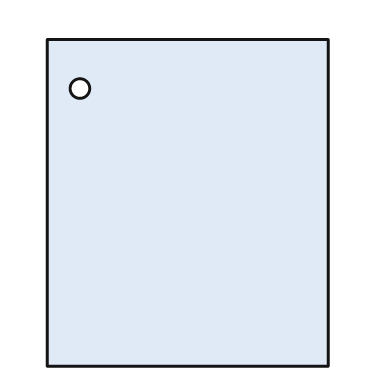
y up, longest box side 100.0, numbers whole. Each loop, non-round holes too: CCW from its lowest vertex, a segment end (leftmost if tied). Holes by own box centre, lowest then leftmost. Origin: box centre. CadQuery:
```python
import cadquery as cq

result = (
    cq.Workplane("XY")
    .moveTo(-43.0, -50.0)
    .lineTo(43.0, -50.0)
    .lineTo(43.0, 50.0)
    .lineTo(-43.0, 50.0)
    .close()
    .moveTo(-33.0, 35.0)
    .circle(3.0)
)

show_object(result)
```